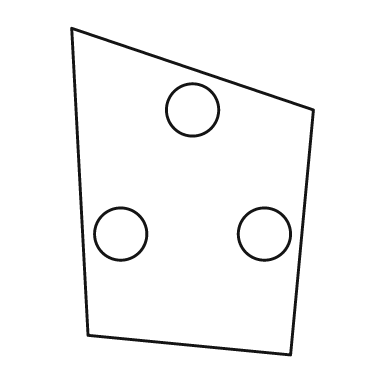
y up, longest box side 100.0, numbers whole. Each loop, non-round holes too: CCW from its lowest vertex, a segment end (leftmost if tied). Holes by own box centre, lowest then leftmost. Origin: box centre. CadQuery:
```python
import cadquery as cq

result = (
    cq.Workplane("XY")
    .moveTo(30.0, -50.0)
    .lineTo(37.0, 25.0)
    .lineTo(-37.0, 50.0)
    .lineTo(-32.0, -44.0)
    .close()
    .moveTo(-22.0, -13.0)
    .circle(8.0)
    .moveTo(22.0, -13.0)
    .circle(8.0)
    .moveTo(0.0, 25.0)
    .circle(8.0)
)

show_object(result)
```